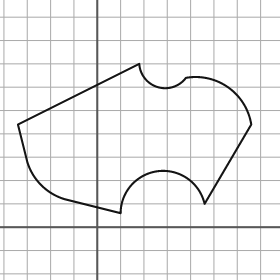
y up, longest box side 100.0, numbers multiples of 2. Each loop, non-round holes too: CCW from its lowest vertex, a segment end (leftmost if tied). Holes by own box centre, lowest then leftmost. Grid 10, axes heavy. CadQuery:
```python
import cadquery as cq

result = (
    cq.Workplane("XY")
    .moveTo(10.0, 6.0)
    .threePointArc((26.0, 24.0), (46.0, 10.0))
    .lineTo(66.0, 44.0)
    .threePointArc((56.0, 60.0), (38.0, 64.0))
    .threePointArc((26.0, 60.0), (18.0, 70.0))
    .lineTo(-34.0, 44.0)
    .lineTo(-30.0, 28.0)
    .threePointArc((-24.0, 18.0), (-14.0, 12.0))
    .close()
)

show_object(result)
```